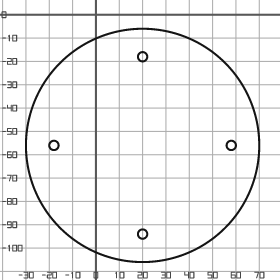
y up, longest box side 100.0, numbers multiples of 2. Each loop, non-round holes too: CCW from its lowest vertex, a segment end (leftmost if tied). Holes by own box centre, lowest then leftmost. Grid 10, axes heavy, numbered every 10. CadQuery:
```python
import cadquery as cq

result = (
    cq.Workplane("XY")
    .moveTo(20.0, -56.0)
    .circle(50.0)
    .moveTo(20.0, -94.0)
    .circle(2.0)
    .moveTo(-18.0, -56.0)
    .circle(2.0)
    .moveTo(58.0, -56.0)
    .circle(2.0)
    .moveTo(20.0, -18.0)
    .circle(2.0)
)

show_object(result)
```